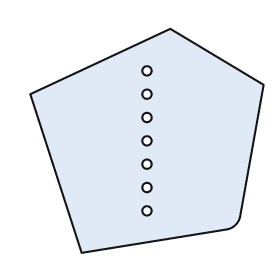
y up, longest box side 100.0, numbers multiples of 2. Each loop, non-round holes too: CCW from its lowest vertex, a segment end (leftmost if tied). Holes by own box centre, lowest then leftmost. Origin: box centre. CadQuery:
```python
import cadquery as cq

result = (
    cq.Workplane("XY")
    .moveTo(-28.0, -48.0)
    .lineTo(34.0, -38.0)
    .threePointArc((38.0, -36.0), (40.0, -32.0))
    .lineTo(50.0, 24.0)
    .lineTo(10.0, 48.0)
    .lineTo(-50.0, 20.0)
    .close()
    .moveTo(0.0, -30.0)
    .circle(2.0)
    .moveTo(0.0, -20.0)
    .circle(2.0)
    .moveTo(0.0, -10.0)
    .circle(2.0)
    .moveTo(0.0, 0.0)
    .circle(2.0)
    .moveTo(0.0, 10.0)
    .circle(2.0)
    .moveTo(0.0, 20.0)
    .circle(2.0)
    .moveTo(0.0, 30.0)
    .circle(2.0)
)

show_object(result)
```